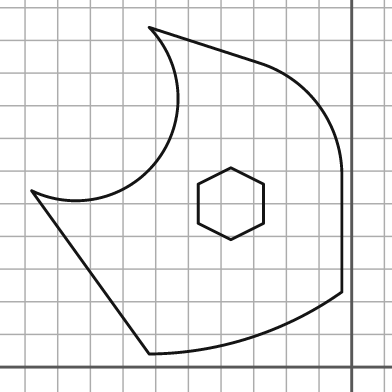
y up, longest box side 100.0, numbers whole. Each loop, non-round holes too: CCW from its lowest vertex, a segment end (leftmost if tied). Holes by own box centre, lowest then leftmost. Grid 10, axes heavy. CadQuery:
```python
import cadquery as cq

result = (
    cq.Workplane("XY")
    .moveTo(-62.0, 4.0)
    .threePointArc((-31.0, 9.0), (-3.0, 23.0))
    .lineTo(-3.0, 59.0)
    .threePointArc((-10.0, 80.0), (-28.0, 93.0))
    .lineTo(-62.0, 104.0)
    .threePointArc((-59.0, 64.0), (-98.0, 54.0))
    .close()
    .moveTo(-37.0, 39.0)
    .lineTo(-27.0, 44.0)
    .lineTo(-27.0, 56.0)
    .lineTo(-37.0, 61.0)
    .lineTo(-47.0, 56.0)
    .lineTo(-47.0, 44.0)
    .close()
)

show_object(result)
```